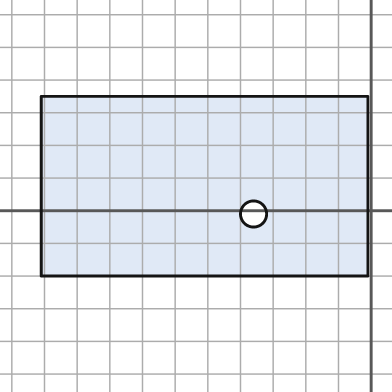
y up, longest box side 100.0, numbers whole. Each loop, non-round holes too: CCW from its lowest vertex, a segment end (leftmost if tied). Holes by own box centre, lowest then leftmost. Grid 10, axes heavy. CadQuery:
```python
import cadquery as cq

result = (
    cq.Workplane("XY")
    .moveTo(-101.0, -20.0)
    .lineTo(-1.0, -20.0)
    .lineTo(-1.0, 35.0)
    .lineTo(-101.0, 35.0)
    .close()
    .moveTo(-36.0, -1.0)
    .circle(4.0)
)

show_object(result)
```